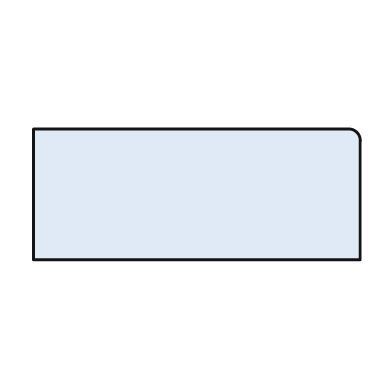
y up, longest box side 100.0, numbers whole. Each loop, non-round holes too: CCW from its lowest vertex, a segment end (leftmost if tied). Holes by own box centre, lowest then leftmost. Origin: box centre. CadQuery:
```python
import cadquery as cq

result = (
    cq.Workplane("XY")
    .moveTo(-50.0, -20.0)
    .lineTo(50.0, -20.0)
    .lineTo(50.0, 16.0)
    .threePointArc((49.0, 19.0), (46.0, 20.0))
    .lineTo(-50.0, 20.0)
    .close()
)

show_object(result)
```